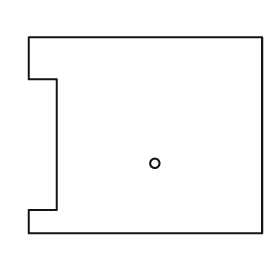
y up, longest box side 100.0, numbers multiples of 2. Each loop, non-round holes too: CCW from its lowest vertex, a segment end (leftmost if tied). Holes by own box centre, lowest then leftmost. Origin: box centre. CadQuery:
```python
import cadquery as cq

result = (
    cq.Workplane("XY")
    .moveTo(-50.0, -42.0)
    .lineTo(50.0, -42.0)
    .lineTo(50.0, 42.0)
    .lineTo(-50.0, 42.0)
    .lineTo(-50.0, 24.0)
    .lineTo(-38.0, 24.0)
    .lineTo(-38.0, -32.0)
    .lineTo(-50.0, -32.0)
    .close()
    .moveTo(4.0, -12.0)
    .circle(2.0)
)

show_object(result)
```